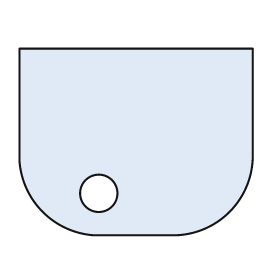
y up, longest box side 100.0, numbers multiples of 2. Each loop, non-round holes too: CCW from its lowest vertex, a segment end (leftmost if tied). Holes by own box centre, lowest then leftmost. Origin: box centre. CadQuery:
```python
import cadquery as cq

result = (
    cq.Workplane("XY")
    .moveTo(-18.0, -40.0)
    .lineTo(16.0, -40.0)
    .threePointArc((40.0, -30.0), (50.0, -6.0))
    .lineTo(50.0, 40.0)
    .lineTo(-50.0, 40.0)
    .lineTo(-50.0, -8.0)
    .threePointArc((-40.0, -30.0), (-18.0, -40.0))
    .close()
    .moveTo(-16.0, -22.0)
    .circle(8.0)
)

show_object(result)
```